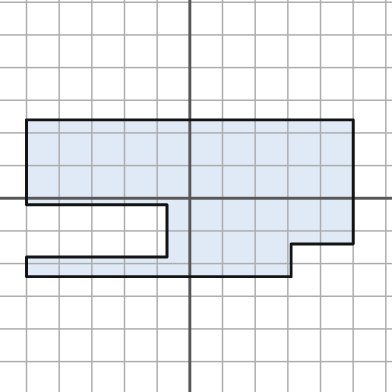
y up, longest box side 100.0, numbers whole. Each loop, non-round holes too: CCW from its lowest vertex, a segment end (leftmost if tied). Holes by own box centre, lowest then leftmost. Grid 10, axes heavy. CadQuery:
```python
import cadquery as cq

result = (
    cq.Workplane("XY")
    .moveTo(-50.0, -24.0)
    .lineTo(31.0, -24.0)
    .lineTo(31.0, -14.0)
    .lineTo(50.0, -14.0)
    .lineTo(50.0, 24.0)
    .lineTo(-50.0, 24.0)
    .lineTo(-50.0, -2.0)
    .lineTo(-7.0, -2.0)
    .lineTo(-7.0, -18.0)
    .lineTo(-50.0, -18.0)
    .close()
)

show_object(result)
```